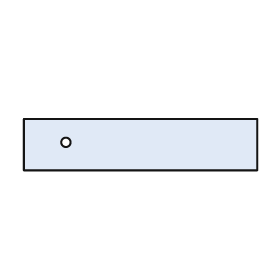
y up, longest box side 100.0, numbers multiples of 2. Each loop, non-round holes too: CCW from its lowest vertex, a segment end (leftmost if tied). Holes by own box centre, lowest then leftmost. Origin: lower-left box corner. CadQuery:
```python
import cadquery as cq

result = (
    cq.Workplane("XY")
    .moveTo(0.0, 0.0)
    .lineTo(100.0, 0.0)
    .lineTo(100.0, 22.0)
    .lineTo(0.0, 22.0)
    .close()
    .moveTo(18.0, 12.0)
    .circle(2.0)
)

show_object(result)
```